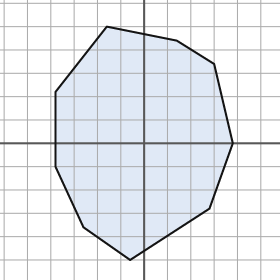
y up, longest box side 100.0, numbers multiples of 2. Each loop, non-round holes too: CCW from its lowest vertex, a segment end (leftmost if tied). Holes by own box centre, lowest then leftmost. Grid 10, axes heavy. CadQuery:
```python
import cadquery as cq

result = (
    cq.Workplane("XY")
    .moveTo(-6.0, -50.0)
    .lineTo(28.0, -28.0)
    .lineTo(38.0, 0.0)
    .lineTo(30.0, 34.0)
    .lineTo(14.0, 44.0)
    .lineTo(-16.0, 50.0)
    .lineTo(-38.0, 22.0)
    .lineTo(-38.0, -10.0)
    .lineTo(-26.0, -36.0)
    .close()
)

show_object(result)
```